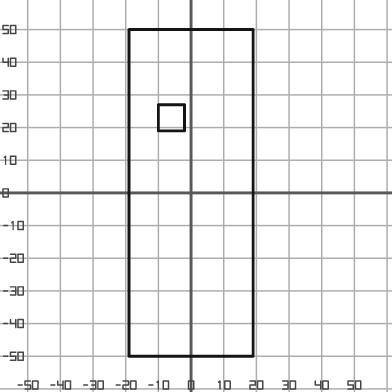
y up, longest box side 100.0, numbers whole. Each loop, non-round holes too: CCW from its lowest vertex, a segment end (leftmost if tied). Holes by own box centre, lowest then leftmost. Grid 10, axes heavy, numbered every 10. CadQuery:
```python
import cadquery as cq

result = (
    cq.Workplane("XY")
    .moveTo(-19.0, -50.0)
    .lineTo(19.0, -50.0)
    .lineTo(19.0, 50.0)
    .lineTo(-19.0, 50.0)
    .close()
    .moveTo(-10.0, 19.0)
    .lineTo(-2.0, 19.0)
    .lineTo(-2.0, 27.0)
    .lineTo(-10.0, 27.0)
    .close()
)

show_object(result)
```